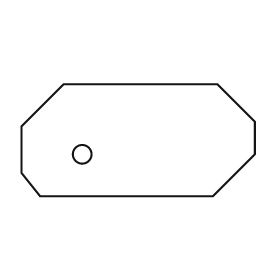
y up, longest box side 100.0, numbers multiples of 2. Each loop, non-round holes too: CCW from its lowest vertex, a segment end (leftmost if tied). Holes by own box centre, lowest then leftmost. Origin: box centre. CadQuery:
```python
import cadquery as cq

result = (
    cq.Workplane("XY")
    .moveTo(-42.0, -24.0)
    .lineTo(32.0, -24.0)
    .lineTo(50.0, -6.0)
    .lineTo(50.0, 8.0)
    .lineTo(34.0, 24.0)
    .lineTo(-32.0, 24.0)
    .lineTo(-50.0, 6.0)
    .lineTo(-50.0, -14.0)
    .close()
    .moveTo(-24.0, -6.0)
    .circle(4.0)
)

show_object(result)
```